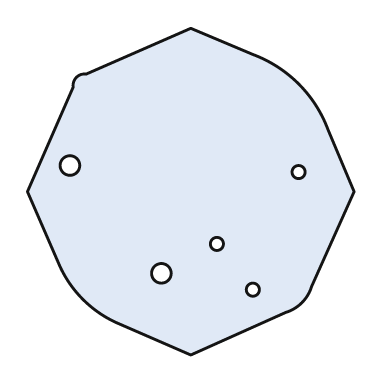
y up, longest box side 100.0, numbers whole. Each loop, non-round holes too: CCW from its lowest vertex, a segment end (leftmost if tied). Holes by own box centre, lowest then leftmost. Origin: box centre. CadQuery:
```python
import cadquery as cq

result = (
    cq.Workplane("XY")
    .moveTo(0.0, -50.0)
    .lineTo(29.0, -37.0)
    .threePointArc((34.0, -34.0), (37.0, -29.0))
    .lineTo(50.0, 0.0)
    .lineTo(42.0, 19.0)
    .threePointArc((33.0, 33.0), (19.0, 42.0))
    .lineTo(0.0, 50.0)
    .lineTo(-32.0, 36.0)
    .threePointArc((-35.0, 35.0), (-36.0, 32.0))
    .lineTo(-50.0, 0.0)
    .lineTo(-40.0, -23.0)
    .threePointArc((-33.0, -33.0), (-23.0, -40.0))
    .close()
    .moveTo(19.0, -30.0)
    .circle(2.0)
    .moveTo(-9.0, -25.0)
    .circle(3.0)
    .moveTo(8.0, -16.0)
    .circle(2.0)
    .moveTo(33.0, 6.0)
    .circle(2.0)
    .moveTo(-37.0, 8.0)
    .circle(3.0)
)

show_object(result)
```